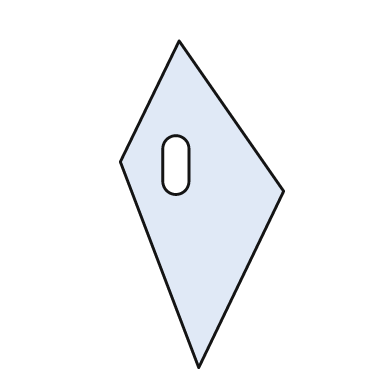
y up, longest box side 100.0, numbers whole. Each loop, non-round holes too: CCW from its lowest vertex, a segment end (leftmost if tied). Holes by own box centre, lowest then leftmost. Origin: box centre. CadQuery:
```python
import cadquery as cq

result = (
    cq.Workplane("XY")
    .moveTo(-1.0, -50.0)
    .lineTo(25.0, 4.0)
    .lineTo(-7.0, 50.0)
    .lineTo(-25.0, 13.0)
    .close()
    .moveTo(-12.0, 7.0)
    .threePointArc((-8.0, 3.0), (-4.0, 7.0))
    .lineTo(-4.0, 17.0)
    .threePointArc((-8.0, 21.0), (-12.0, 17.0))
    .close()
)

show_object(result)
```